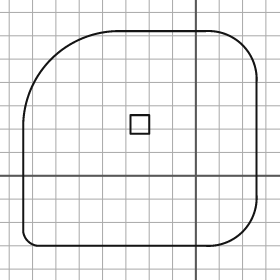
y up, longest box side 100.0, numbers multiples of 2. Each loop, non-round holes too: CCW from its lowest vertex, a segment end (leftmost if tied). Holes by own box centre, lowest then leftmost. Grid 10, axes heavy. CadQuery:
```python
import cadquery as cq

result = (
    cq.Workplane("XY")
    .moveTo(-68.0, -30.0)
    .lineTo(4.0, -30.0)
    .threePointArc((20.0, -24.0), (26.0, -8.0))
    .lineTo(26.0, 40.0)
    .threePointArc((20.0, 56.0), (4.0, 62.0))
    .lineTo(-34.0, 62.0)
    .threePointArc((-62.0, 50.0), (-74.0, 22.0))
    .lineTo(-74.0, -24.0)
    .threePointArc((-72.0, -28.0), (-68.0, -30.0))
    .close()
    .moveTo(-28.0, 18.0)
    .lineTo(-20.0, 18.0)
    .lineTo(-20.0, 26.0)
    .lineTo(-28.0, 26.0)
    .close()
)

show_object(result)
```